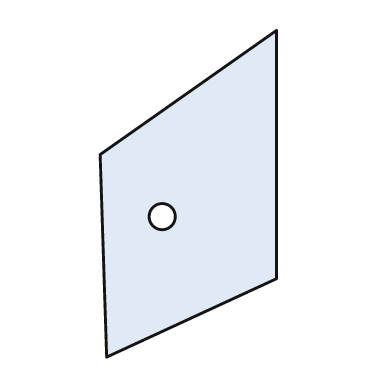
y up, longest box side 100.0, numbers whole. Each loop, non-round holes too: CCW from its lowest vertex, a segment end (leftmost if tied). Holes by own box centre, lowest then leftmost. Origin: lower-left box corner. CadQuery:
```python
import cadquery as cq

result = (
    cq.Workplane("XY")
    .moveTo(2.0, 0.0)
    .lineTo(54.0, 24.0)
    .lineTo(54.0, 100.0)
    .lineTo(0.0, 62.0)
    .close()
    .moveTo(19.0, 43.0)
    .circle(4.0)
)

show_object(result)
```